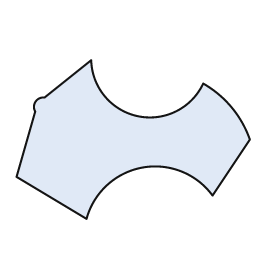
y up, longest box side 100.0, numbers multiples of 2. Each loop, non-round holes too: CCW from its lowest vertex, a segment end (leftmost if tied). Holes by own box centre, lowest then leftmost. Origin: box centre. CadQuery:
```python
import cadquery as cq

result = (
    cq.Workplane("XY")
    .moveTo(-20.0, -34.0)
    .threePointArc((4.0, -12.0), (34.0, -24.0))
    .lineTo(50.0, 0.0)
    .threePointArc((42.0, 14.0), (30.0, 24.0))
    .threePointArc((2.0, 10.0), (-18.0, 34.0))
    .lineTo(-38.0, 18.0)
    .threePointArc((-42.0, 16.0), (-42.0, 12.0))
    .lineTo(-50.0, -16.0)
    .close()
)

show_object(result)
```